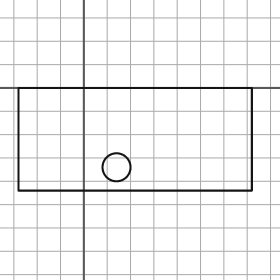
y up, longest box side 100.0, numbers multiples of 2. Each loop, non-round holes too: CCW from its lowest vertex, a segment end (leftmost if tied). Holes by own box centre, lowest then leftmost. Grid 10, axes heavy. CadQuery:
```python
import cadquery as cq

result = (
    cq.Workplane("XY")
    .moveTo(-28.0, -44.0)
    .lineTo(72.0, -44.0)
    .lineTo(72.0, 0.0)
    .lineTo(-28.0, 0.0)
    .close()
    .moveTo(14.0, -34.0)
    .circle(6.0)
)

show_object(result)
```